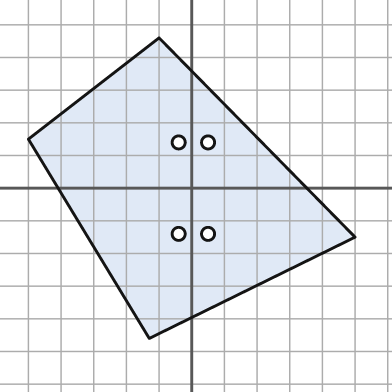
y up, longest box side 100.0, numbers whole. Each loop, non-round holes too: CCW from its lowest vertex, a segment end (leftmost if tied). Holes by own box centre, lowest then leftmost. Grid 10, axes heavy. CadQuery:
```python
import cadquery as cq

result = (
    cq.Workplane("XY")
    .moveTo(-13.0, -46.0)
    .lineTo(50.0, -15.0)
    .lineTo(-10.0, 46.0)
    .lineTo(-50.0, 15.0)
    .close()
    .moveTo(-4.0, -14.0)
    .circle(2.0)
    .moveTo(5.0, -14.0)
    .circle(2.0)
    .moveTo(-4.0, 14.0)
    .circle(2.0)
    .moveTo(5.0, 14.0)
    .circle(2.0)
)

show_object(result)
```